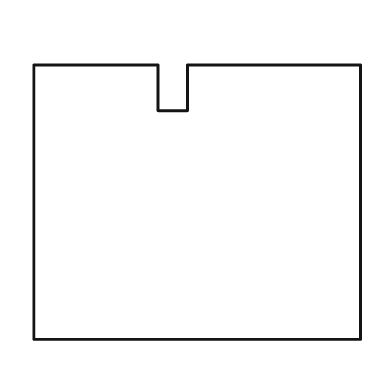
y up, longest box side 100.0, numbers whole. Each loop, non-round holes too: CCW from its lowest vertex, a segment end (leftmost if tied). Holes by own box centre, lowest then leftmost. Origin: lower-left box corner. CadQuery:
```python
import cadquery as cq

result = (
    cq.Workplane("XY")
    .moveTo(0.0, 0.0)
    .lineTo(100.0, 0.0)
    .lineTo(100.0, 84.0)
    .lineTo(47.0, 84.0)
    .lineTo(47.0, 70.0)
    .lineTo(38.0, 70.0)
    .lineTo(38.0, 84.0)
    .lineTo(0.0, 84.0)
    .close()
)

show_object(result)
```